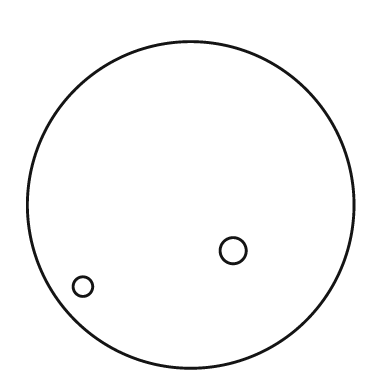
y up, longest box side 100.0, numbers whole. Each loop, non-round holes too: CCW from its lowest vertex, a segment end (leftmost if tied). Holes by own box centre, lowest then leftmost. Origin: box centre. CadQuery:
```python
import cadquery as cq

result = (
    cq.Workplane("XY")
    .moveTo(0.0, 0.0)
    .circle(50.0)
    .moveTo(-33.0, -25.0)
    .circle(3.0)
    .moveTo(13.0, -14.0)
    .circle(4.0)
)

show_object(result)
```